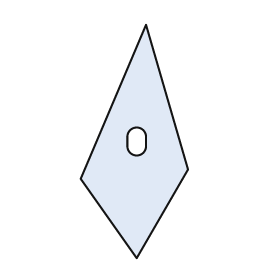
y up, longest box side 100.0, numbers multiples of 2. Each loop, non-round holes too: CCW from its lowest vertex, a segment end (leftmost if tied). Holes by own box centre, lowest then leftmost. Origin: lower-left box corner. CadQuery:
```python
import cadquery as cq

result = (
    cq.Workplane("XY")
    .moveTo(24.0, 0.0)
    .lineTo(46.0, 38.0)
    .lineTo(28.0, 100.0)
    .lineTo(0.0, 34.0)
    .close()
    .moveTo(20.0, 48.0)
    .threePointArc((24.0, 44.0), (28.0, 48.0))
    .lineTo(28.0, 52.0)
    .threePointArc((24.0, 56.0), (20.0, 52.0))
    .close()
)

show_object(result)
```